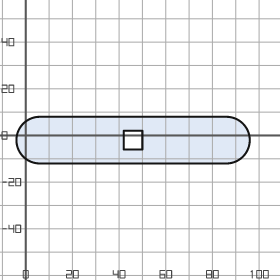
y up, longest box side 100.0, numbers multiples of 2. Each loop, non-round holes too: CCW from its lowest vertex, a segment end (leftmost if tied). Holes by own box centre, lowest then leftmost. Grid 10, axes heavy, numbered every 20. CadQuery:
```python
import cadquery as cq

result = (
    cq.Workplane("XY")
    .moveTo(6.0, -12.0)
    .lineTo(86.0, -12.0)
    .threePointArc((96.0, -2.0), (86.0, 8.0))
    .lineTo(6.0, 8.0)
    .threePointArc((-4.0, -2.0), (6.0, -12.0))
    .close()
    .moveTo(42.0, -6.0)
    .lineTo(50.0, -6.0)
    .lineTo(50.0, 2.0)
    .lineTo(42.0, 2.0)
    .close()
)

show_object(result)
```